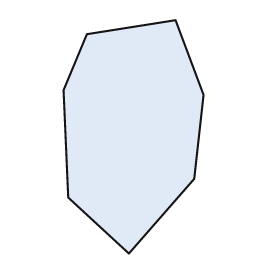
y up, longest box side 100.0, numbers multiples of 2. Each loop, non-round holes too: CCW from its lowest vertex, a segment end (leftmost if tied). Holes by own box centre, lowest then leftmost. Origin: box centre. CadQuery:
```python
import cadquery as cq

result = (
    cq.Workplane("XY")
    .moveTo(-2.0, -50.0)
    .lineTo(26.0, -18.0)
    .lineTo(30.0, 18.0)
    .lineTo(18.0, 50.0)
    .lineTo(-20.0, 44.0)
    .lineTo(-30.0, 20.0)
    .lineTo(-28.0, -26.0)
    .close()
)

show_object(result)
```